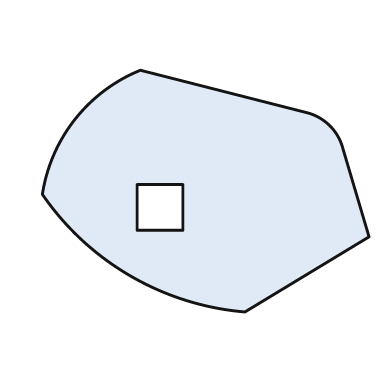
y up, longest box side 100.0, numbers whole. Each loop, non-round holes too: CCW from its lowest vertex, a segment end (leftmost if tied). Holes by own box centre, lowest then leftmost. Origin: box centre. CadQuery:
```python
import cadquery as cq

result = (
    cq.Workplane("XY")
    .moveTo(12.0, -37.0)
    .lineTo(50.0, -14.0)
    .lineTo(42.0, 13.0)
    .threePointArc((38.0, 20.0), (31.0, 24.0))
    .lineTo(-20.0, 37.0)
    .threePointArc((-40.0, 22.0), (-50.0, -1.0))
    .threePointArc((-23.0, -26.0), (12.0, -37.0))
    .close()
    .moveTo(-21.0, -12.0)
    .lineTo(-7.0, -12.0)
    .lineTo(-7.0, 2.0)
    .lineTo(-21.0, 2.0)
    .close()
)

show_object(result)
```